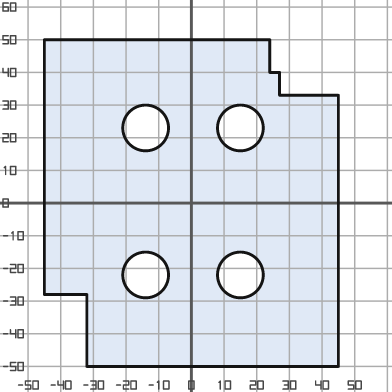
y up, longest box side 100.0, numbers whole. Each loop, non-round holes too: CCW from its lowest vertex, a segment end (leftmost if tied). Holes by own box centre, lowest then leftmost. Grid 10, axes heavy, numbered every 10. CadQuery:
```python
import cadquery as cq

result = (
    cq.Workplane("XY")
    .moveTo(-32.0, -50.0)
    .lineTo(45.0, -50.0)
    .lineTo(45.0, 33.0)
    .lineTo(27.0, 33.0)
    .lineTo(27.0, 40.0)
    .lineTo(24.0, 40.0)
    .lineTo(24.0, 50.0)
    .lineTo(-45.0, 50.0)
    .lineTo(-45.0, -28.0)
    .lineTo(-32.0, -28.0)
    .close()
    .moveTo(-14.0, -22.0)
    .circle(7.0)
    .moveTo(15.0, -22.0)
    .circle(7.0)
    .moveTo(-14.0, 23.0)
    .circle(7.0)
    .moveTo(15.0, 23.0)
    .circle(7.0)
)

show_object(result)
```